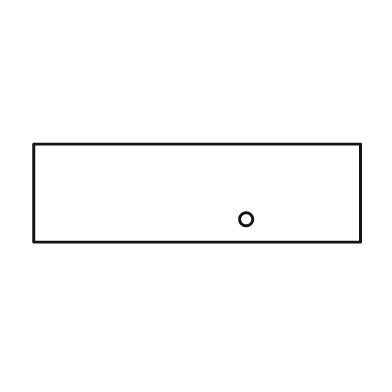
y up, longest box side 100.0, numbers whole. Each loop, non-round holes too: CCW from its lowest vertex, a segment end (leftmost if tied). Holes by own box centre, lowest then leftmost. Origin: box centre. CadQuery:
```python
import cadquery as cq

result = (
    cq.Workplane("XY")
    .moveTo(-50.0, -15.0)
    .lineTo(50.0, -15.0)
    .lineTo(50.0, 15.0)
    .lineTo(-50.0, 15.0)
    .close()
    .moveTo(15.0, -8.0)
    .circle(2.0)
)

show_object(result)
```